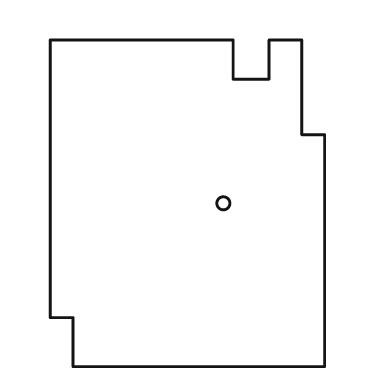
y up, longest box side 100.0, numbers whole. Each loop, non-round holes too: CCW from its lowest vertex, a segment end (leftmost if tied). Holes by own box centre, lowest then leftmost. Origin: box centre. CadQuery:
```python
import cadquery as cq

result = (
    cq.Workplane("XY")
    .moveTo(-35.0, -50.0)
    .lineTo(42.0, -50.0)
    .lineTo(42.0, 21.0)
    .lineTo(35.0, 21.0)
    .lineTo(35.0, 50.0)
    .lineTo(25.0, 50.0)
    .lineTo(25.0, 38.0)
    .lineTo(14.0, 38.0)
    .lineTo(14.0, 50.0)
    .lineTo(-42.0, 50.0)
    .lineTo(-42.0, -35.0)
    .lineTo(-35.0, -35.0)
    .close()
    .moveTo(11.0, 0.0)
    .circle(2.0)
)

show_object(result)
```